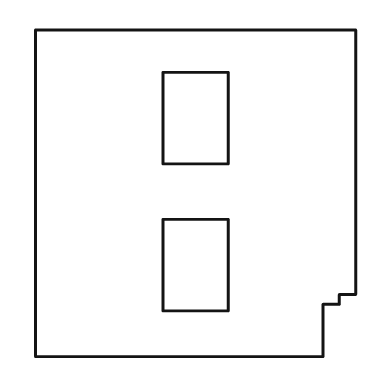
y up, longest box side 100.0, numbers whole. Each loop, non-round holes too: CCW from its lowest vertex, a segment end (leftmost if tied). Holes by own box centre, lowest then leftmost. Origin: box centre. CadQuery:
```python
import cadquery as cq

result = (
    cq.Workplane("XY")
    .moveTo(-49.0, -50.0)
    .lineTo(39.0, -50.0)
    .lineTo(39.0, -34.0)
    .lineTo(44.0, -34.0)
    .lineTo(44.0, -31.0)
    .lineTo(49.0, -31.0)
    .lineTo(49.0, 50.0)
    .lineTo(-49.0, 50.0)
    .close()
    .moveTo(-10.0, -36.0)
    .lineTo(10.0, -36.0)
    .lineTo(10.0, -8.0)
    .lineTo(-10.0, -8.0)
    .close()
    .moveTo(-10.0, 9.0)
    .lineTo(10.0, 9.0)
    .lineTo(10.0, 37.0)
    .lineTo(-10.0, 37.0)
    .close()
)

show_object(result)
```